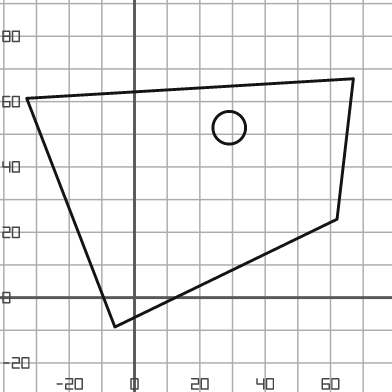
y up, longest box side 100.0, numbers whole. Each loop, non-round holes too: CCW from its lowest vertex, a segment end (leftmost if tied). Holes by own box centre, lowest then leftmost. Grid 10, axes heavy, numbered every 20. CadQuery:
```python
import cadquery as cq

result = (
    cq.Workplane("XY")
    .moveTo(-6.0, -9.0)
    .lineTo(62.0, 24.0)
    .lineTo(67.0, 67.0)
    .lineTo(-33.0, 61.0)
    .close()
    .moveTo(29.0, 52.0)
    .circle(5.0)
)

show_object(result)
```